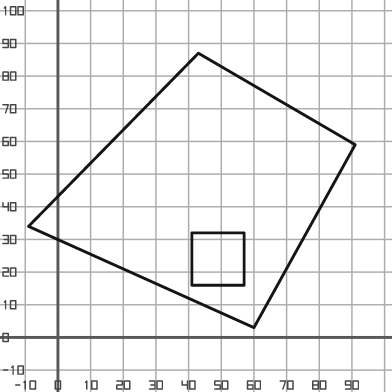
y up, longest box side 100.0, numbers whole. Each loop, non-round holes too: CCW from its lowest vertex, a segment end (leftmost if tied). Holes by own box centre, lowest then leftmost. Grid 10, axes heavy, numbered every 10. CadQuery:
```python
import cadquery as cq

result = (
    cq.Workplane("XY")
    .moveTo(60.0, 3.0)
    .lineTo(91.0, 59.0)
    .lineTo(43.0, 87.0)
    .lineTo(-9.0, 34.0)
    .close()
    .moveTo(41.0, 16.0)
    .lineTo(57.0, 16.0)
    .lineTo(57.0, 32.0)
    .lineTo(41.0, 32.0)
    .close()
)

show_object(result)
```